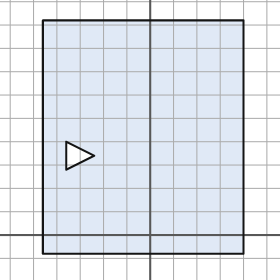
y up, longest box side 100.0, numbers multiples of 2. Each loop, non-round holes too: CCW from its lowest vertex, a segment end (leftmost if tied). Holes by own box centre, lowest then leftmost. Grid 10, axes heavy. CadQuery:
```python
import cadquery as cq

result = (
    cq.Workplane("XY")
    .moveTo(-46.0, -8.0)
    .lineTo(40.0, -8.0)
    .lineTo(40.0, 92.0)
    .lineTo(-46.0, 92.0)
    .close()
    .moveTo(-36.0, 28.0)
    .lineTo(-24.0, 34.0)
    .lineTo(-36.0, 40.0)
    .close()
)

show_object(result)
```